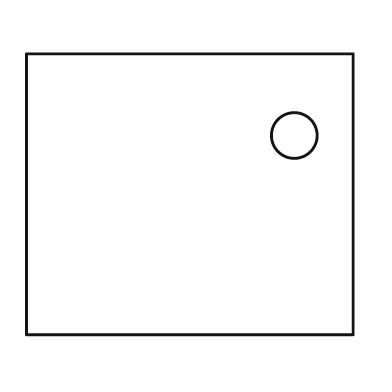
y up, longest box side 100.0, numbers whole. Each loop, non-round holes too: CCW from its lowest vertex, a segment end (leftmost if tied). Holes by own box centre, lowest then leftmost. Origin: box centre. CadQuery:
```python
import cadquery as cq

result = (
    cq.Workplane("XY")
    .moveTo(-50.0, -43.0)
    .lineTo(50.0, -43.0)
    .lineTo(50.0, 43.0)
    .lineTo(-50.0, 43.0)
    .close()
    .moveTo(32.0, 18.0)
    .circle(7.0)
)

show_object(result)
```